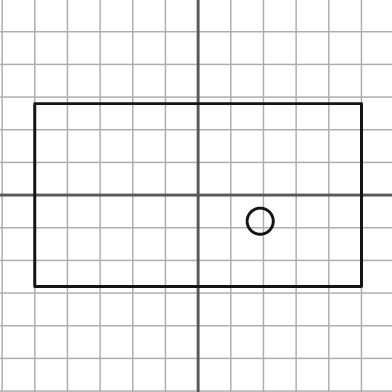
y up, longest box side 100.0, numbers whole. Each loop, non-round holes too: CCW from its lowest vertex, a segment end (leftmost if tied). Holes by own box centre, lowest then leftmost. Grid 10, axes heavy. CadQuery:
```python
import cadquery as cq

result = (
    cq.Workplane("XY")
    .moveTo(-50.0, -28.0)
    .lineTo(50.0, -28.0)
    .lineTo(50.0, 28.0)
    .lineTo(-50.0, 28.0)
    .close()
    .moveTo(19.0, -8.0)
    .circle(4.0)
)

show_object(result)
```